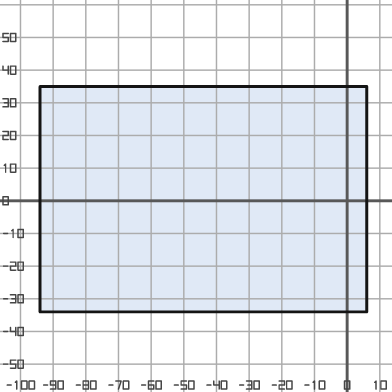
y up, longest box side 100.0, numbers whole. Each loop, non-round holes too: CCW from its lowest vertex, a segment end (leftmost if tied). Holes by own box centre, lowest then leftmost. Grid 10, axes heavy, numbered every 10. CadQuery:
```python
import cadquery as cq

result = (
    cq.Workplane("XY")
    .moveTo(-94.0, -34.0)
    .lineTo(6.0, -34.0)
    .lineTo(6.0, 35.0)
    .lineTo(-94.0, 35.0)
    .close()
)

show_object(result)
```